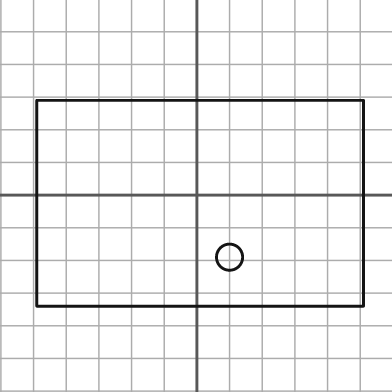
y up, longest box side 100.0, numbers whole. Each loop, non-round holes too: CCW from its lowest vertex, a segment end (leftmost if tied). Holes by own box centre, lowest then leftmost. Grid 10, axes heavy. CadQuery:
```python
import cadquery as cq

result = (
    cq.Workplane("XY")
    .moveTo(-49.0, -34.0)
    .lineTo(51.0, -34.0)
    .lineTo(51.0, 29.0)
    .lineTo(-49.0, 29.0)
    .close()
    .moveTo(10.0, -19.0)
    .circle(4.0)
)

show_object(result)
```